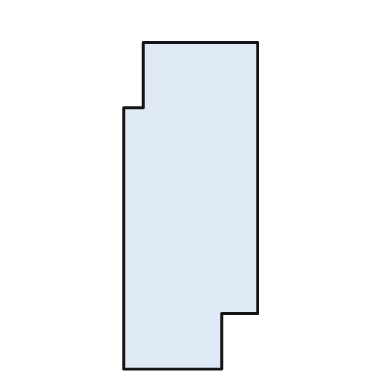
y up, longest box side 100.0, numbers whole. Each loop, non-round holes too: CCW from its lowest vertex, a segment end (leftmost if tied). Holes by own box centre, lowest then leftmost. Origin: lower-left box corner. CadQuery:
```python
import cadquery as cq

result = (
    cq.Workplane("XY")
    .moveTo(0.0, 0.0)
    .lineTo(30.0, 0.0)
    .lineTo(30.0, 17.0)
    .lineTo(41.0, 17.0)
    .lineTo(41.0, 100.0)
    .lineTo(6.0, 100.0)
    .lineTo(6.0, 80.0)
    .lineTo(0.0, 80.0)
    .close()
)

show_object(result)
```